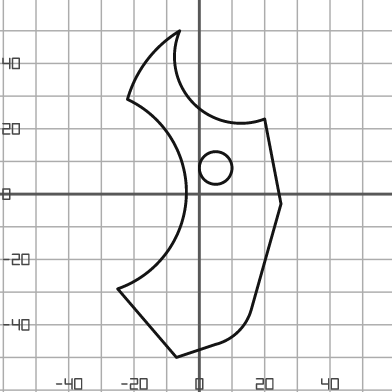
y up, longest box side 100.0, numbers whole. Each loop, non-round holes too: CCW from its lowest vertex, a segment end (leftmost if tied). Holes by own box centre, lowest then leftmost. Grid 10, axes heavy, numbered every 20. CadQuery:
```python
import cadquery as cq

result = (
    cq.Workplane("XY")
    .moveTo(-7.0, -50.0)
    .lineTo(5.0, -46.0)
    .threePointArc((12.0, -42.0), (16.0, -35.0))
    .lineTo(25.0, -3.0)
    .lineTo(20.0, 23.0)
    .threePointArc((-2.0, 28.0), (-6.0, 50.0))
    .threePointArc((-16.0, 41.0), (-22.0, 29.0))
    .threePointArc((-4.0, -1.0), (-25.0, -29.0))
    .close()
    .moveTo(5.0, 8.0)
    .circle(5.0)
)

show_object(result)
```